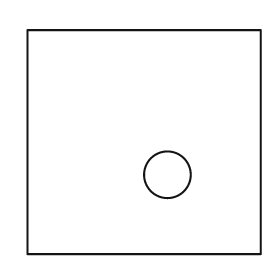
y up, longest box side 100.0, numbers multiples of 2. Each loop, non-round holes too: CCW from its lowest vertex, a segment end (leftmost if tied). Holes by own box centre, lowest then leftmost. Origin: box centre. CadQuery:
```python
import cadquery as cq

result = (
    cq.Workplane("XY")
    .moveTo(-50.0, -48.0)
    .lineTo(50.0, -48.0)
    .lineTo(50.0, 48.0)
    .lineTo(-50.0, 48.0)
    .close()
    .moveTo(10.0, -14.0)
    .circle(10.0)
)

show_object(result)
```